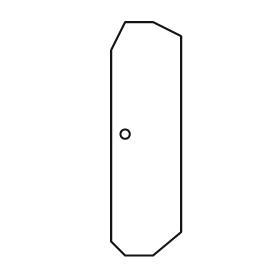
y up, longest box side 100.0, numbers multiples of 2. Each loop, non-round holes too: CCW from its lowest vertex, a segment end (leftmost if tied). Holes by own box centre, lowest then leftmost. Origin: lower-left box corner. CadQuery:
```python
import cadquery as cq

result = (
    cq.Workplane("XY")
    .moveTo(6.0, 0.0)
    .lineTo(18.0, 0.0)
    .lineTo(30.0, 10.0)
    .lineTo(30.0, 94.0)
    .lineTo(18.0, 100.0)
    .lineTo(6.0, 100.0)
    .lineTo(0.0, 88.0)
    .lineTo(0.0, 6.0)
    .close()
    .moveTo(6.0, 52.0)
    .circle(2.0)
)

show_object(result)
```